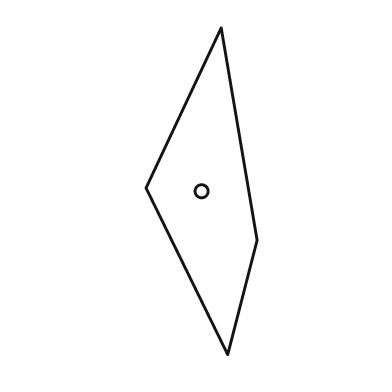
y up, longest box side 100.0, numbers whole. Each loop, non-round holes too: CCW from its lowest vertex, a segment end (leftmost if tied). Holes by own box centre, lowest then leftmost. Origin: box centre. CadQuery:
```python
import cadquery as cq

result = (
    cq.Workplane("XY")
    .moveTo(8.0, -50.0)
    .lineTo(17.0, -15.0)
    .lineTo(6.0, 50.0)
    .lineTo(-17.0, 1.0)
    .close()
    .moveTo(0.0, 0.0)
    .circle(2.0)
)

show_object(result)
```